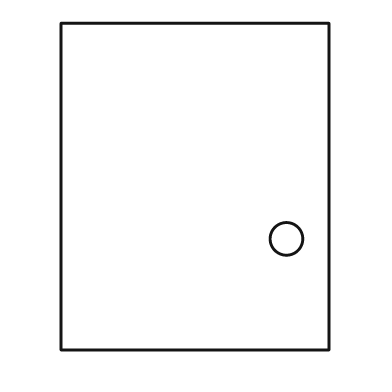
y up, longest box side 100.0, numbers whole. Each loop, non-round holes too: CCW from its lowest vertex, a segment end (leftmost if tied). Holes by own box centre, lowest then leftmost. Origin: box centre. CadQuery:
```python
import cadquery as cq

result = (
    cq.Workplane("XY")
    .moveTo(-41.0, -50.0)
    .lineTo(41.0, -50.0)
    .lineTo(41.0, 50.0)
    .lineTo(-41.0, 50.0)
    .close()
    .moveTo(28.0, -16.0)
    .circle(5.0)
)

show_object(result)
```